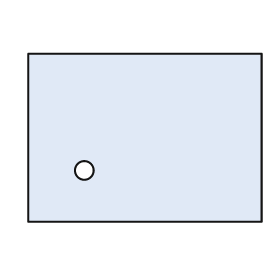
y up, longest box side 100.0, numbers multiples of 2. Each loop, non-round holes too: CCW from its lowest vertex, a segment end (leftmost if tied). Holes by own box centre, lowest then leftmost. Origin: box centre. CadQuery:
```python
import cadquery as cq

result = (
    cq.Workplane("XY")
    .moveTo(-50.0, -36.0)
    .lineTo(50.0, -36.0)
    .lineTo(50.0, 36.0)
    .lineTo(-50.0, 36.0)
    .close()
    .moveTo(-26.0, -14.0)
    .circle(4.0)
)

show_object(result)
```